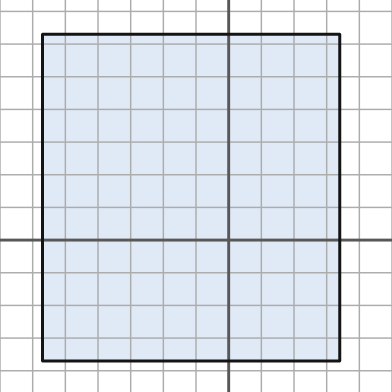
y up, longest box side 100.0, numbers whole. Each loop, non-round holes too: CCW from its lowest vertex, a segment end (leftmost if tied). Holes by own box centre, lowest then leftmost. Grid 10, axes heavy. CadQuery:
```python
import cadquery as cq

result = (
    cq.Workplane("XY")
    .moveTo(-57.0, -37.0)
    .lineTo(34.0, -37.0)
    .lineTo(34.0, 63.0)
    .lineTo(-57.0, 63.0)
    .close()
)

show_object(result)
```